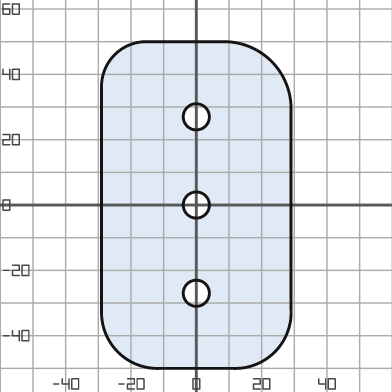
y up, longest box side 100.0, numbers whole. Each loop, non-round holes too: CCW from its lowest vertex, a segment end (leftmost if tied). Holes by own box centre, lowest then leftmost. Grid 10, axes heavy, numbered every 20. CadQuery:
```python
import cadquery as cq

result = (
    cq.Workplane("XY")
    .moveTo(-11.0, -50.0)
    .lineTo(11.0, -50.0)
    .threePointArc((24.0, -45.0), (29.0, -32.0))
    .lineTo(29.0, 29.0)
    .threePointArc((23.0, 44.0), (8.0, 50.0))
    .lineTo(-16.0, 50.0)
    .threePointArc((-25.0, 46.0), (-29.0, 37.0))
    .lineTo(-29.0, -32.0)
    .threePointArc((-24.0, -45.0), (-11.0, -50.0))
    .close()
    .moveTo(0.0, -27.0)
    .circle(4.0)
    .moveTo(0.0, 0.0)
    .circle(4.0)
    .moveTo(0.0, 27.0)
    .circle(4.0)
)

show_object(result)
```